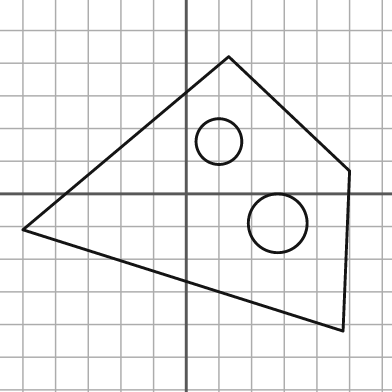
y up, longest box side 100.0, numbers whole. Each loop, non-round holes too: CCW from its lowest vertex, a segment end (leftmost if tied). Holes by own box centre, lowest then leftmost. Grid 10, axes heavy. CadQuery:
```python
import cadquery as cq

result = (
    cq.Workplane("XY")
    .moveTo(48.0, -42.0)
    .lineTo(50.0, 7.0)
    .lineTo(13.0, 42.0)
    .lineTo(-50.0, -11.0)
    .close()
    .moveTo(28.0, -9.0)
    .circle(9.0)
    .moveTo(10.0, 16.0)
    .circle(7.0)
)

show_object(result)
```